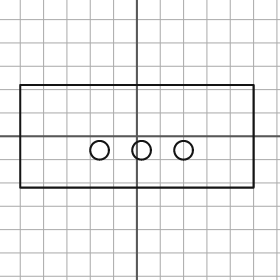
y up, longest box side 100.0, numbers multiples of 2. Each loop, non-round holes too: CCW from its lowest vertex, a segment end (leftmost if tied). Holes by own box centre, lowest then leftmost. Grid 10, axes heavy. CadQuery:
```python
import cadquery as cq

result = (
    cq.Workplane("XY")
    .moveTo(-50.0, -22.0)
    .lineTo(50.0, -22.0)
    .lineTo(50.0, 22.0)
    .lineTo(-50.0, 22.0)
    .close()
    .moveTo(-16.0, -6.0)
    .circle(4.0)
    .moveTo(2.0, -6.0)
    .circle(4.0)
    .moveTo(20.0, -6.0)
    .circle(4.0)
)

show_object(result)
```